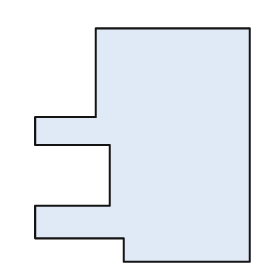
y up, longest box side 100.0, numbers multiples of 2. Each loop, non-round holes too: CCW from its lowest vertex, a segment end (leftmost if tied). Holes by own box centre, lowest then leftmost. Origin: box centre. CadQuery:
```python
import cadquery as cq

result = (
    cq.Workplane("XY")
    .moveTo(-8.0, -50.0)
    .lineTo(46.0, -50.0)
    .lineTo(46.0, 50.0)
    .lineTo(-20.0, 50.0)
    .lineTo(-20.0, 12.0)
    .lineTo(-46.0, 12.0)
    .lineTo(-46.0, 0.0)
    .lineTo(-14.0, 0.0)
    .lineTo(-14.0, -26.0)
    .lineTo(-46.0, -26.0)
    .lineTo(-46.0, -40.0)
    .lineTo(-8.0, -40.0)
    .close()
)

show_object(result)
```